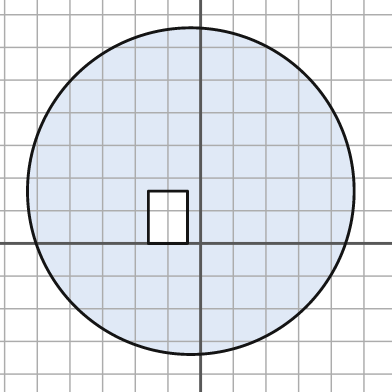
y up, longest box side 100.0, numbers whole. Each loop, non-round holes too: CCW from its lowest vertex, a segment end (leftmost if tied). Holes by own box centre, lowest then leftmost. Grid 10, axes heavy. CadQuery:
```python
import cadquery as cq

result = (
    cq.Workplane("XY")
    .moveTo(-3.0, 16.0)
    .circle(50.0)
    .moveTo(-16.0, 0.0)
    .lineTo(-4.0, 0.0)
    .lineTo(-4.0, 16.0)
    .lineTo(-16.0, 16.0)
    .close()
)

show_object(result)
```